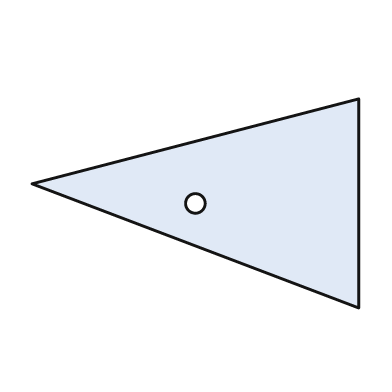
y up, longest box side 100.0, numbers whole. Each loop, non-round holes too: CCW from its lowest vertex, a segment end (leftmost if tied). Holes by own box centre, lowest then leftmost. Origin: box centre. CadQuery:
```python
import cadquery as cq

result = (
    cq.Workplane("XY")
    .moveTo(50.0, -32.0)
    .lineTo(50.0, 32.0)
    .lineTo(-50.0, 6.0)
    .close()
    .moveTo(0.0, 0.0)
    .circle(3.0)
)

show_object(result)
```